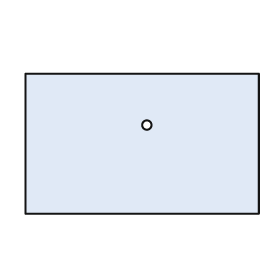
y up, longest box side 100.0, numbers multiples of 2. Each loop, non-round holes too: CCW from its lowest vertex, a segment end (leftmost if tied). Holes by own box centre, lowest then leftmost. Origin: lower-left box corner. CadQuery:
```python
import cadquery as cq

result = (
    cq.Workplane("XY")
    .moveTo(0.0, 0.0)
    .lineTo(100.0, 0.0)
    .lineTo(100.0, 60.0)
    .lineTo(0.0, 60.0)
    .close()
    .moveTo(52.0, 38.0)
    .circle(2.0)
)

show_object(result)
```